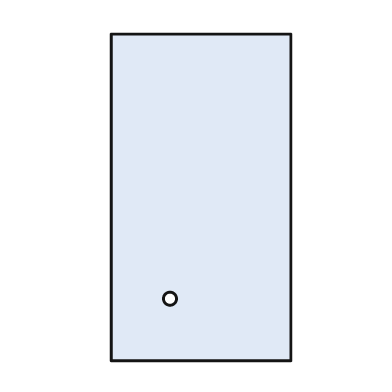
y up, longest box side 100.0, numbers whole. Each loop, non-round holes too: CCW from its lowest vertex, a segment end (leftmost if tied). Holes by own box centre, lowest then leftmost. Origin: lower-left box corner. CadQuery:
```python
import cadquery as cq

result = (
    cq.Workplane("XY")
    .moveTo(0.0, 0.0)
    .lineTo(55.0, 0.0)
    .lineTo(55.0, 100.0)
    .lineTo(0.0, 100.0)
    .close()
    .moveTo(18.0, 19.0)
    .circle(2.0)
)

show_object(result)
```